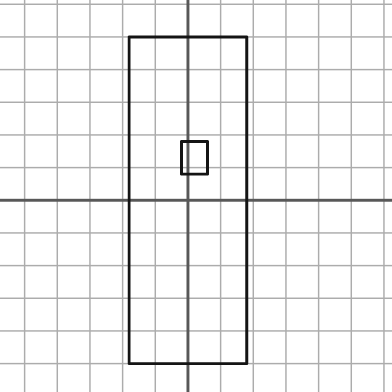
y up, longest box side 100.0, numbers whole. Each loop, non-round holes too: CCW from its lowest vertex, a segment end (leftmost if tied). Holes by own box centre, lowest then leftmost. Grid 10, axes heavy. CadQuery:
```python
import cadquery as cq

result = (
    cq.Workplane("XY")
    .moveTo(-18.0, -50.0)
    .lineTo(18.0, -50.0)
    .lineTo(18.0, 50.0)
    .lineTo(-18.0, 50.0)
    .close()
    .moveTo(-2.0, 8.0)
    .lineTo(6.0, 8.0)
    .lineTo(6.0, 18.0)
    .lineTo(-2.0, 18.0)
    .close()
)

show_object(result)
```